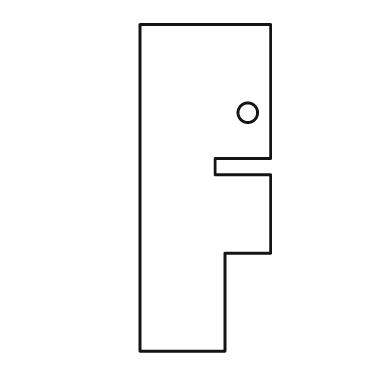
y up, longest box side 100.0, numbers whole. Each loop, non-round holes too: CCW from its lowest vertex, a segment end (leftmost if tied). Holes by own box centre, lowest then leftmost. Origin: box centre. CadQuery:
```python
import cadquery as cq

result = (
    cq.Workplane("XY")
    .moveTo(-20.0, -50.0)
    .lineTo(6.0, -50.0)
    .lineTo(6.0, -20.0)
    .lineTo(20.0, -20.0)
    .lineTo(20.0, 4.0)
    .lineTo(3.0, 4.0)
    .lineTo(3.0, 9.0)
    .lineTo(20.0, 9.0)
    .lineTo(20.0, 50.0)
    .lineTo(-20.0, 50.0)
    .close()
    .moveTo(13.0, 23.0)
    .circle(3.0)
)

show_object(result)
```